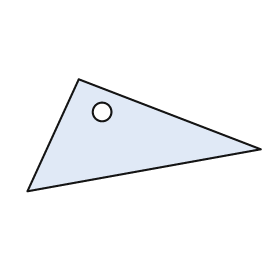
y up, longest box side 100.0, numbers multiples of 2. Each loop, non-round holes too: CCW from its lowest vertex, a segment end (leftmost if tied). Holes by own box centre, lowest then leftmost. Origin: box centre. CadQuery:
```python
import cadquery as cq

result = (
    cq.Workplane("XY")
    .moveTo(-50.0, -24.0)
    .lineTo(50.0, -6.0)
    .lineTo(-28.0, 24.0)
    .close()
    .moveTo(-18.0, 10.0)
    .circle(4.0)
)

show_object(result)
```